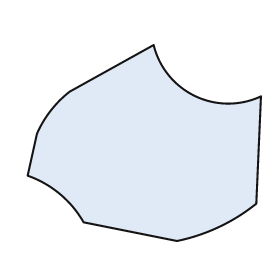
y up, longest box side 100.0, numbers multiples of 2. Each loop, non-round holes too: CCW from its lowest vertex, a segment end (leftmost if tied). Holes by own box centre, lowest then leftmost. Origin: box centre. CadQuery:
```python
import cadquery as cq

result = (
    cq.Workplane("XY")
    .moveTo(14.0, -42.0)
    .threePointArc((32.0, -36.0), (48.0, -26.0))
    .lineTo(50.0, 20.0)
    .threePointArc((22.0, 20.0), (4.0, 42.0))
    .lineTo(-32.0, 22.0)
    .threePointArc((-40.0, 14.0), (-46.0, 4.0))
    .lineTo(-50.0, -14.0)
    .threePointArc((-36.0, -22.0), (-26.0, -34.0))
    .close()
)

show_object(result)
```